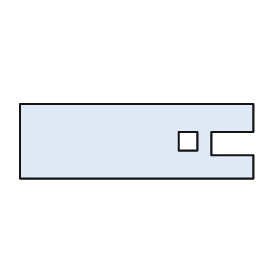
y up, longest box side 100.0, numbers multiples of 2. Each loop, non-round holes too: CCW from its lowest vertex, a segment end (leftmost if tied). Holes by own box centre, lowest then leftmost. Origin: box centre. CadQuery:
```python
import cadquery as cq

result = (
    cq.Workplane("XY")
    .moveTo(-50.0, -16.0)
    .lineTo(50.0, -16.0)
    .lineTo(50.0, -6.0)
    .lineTo(32.0, -6.0)
    .lineTo(32.0, 4.0)
    .lineTo(50.0, 4.0)
    .lineTo(50.0, 16.0)
    .lineTo(-50.0, 16.0)
    .close()
    .moveTo(18.0, -4.0)
    .lineTo(26.0, -4.0)
    .lineTo(26.0, 4.0)
    .lineTo(18.0, 4.0)
    .close()
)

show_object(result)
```